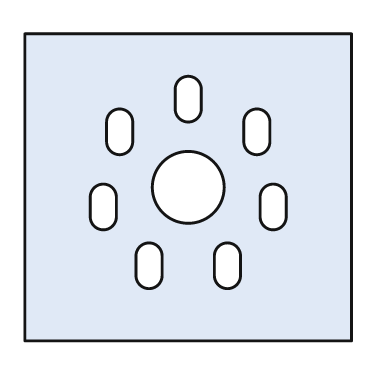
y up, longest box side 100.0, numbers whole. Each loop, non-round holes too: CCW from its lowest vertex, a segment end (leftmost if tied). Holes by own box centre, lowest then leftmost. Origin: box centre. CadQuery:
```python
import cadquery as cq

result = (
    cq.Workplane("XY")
    .moveTo(-50.0, -47.0)
    .lineTo(50.0, -47.0)
    .lineTo(50.0, 47.0)
    .lineTo(-50.0, 47.0)
    .close()
    .moveTo(-16.0, -27.0)
    .threePointArc((-12.0, -31.0), (-8.0, -27.0))
    .lineTo(-8.0, -21.0)
    .threePointArc((-12.0, -17.0), (-16.0, -21.0))
    .close()
    .moveTo(8.0, -27.0)
    .threePointArc((12.0, -31.0), (16.0, -27.0))
    .lineTo(16.0, -21.0)
    .threePointArc((12.0, -17.0), (8.0, -21.0))
    .close()
    .moveTo(-30.0, -9.0)
    .threePointArc((-26.0, -13.0), (-22.0, -9.0))
    .lineTo(-22.0, -3.0)
    .threePointArc((-26.0, 1.0), (-30.0, -3.0))
    .close()
    .moveTo(22.0, -9.0)
    .threePointArc((26.0, -13.0), (30.0, -9.0))
    .lineTo(30.0, -3.0)
    .threePointArc((26.0, 1.0), (22.0, -3.0))
    .close()
    .moveTo(0.0, 0.0)
    .circle(11.0)
    .moveTo(-25.0, 14.0)
    .threePointArc((-21.0, 10.0), (-17.0, 14.0))
    .lineTo(-17.0, 20.0)
    .threePointArc((-21.0, 24.0), (-25.0, 20.0))
    .close()
    .moveTo(17.0, 14.0)
    .threePointArc((21.0, 10.0), (25.0, 14.0))
    .lineTo(25.0, 20.0)
    .threePointArc((21.0, 24.0), (17.0, 20.0))
    .close()
    .moveTo(-4.0, 24.0)
    .threePointArc((0.0, 20.0), (4.0, 24.0))
    .lineTo(4.0, 30.0)
    .threePointArc((0.0, 34.0), (-4.0, 30.0))
    .close()
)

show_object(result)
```